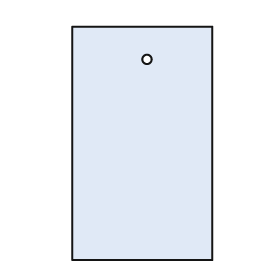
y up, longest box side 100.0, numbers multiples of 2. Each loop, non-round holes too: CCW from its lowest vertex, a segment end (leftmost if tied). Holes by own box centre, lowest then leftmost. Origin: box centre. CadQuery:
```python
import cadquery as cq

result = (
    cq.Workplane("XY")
    .moveTo(-30.0, -50.0)
    .lineTo(30.0, -50.0)
    .lineTo(30.0, 50.0)
    .lineTo(-30.0, 50.0)
    .close()
    .moveTo(2.0, 36.0)
    .circle(2.0)
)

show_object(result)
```